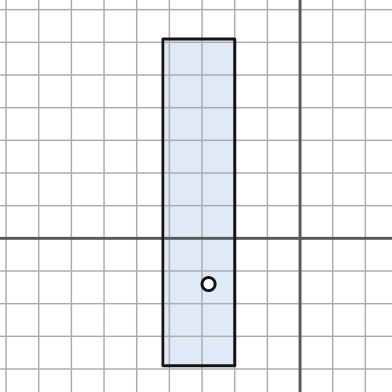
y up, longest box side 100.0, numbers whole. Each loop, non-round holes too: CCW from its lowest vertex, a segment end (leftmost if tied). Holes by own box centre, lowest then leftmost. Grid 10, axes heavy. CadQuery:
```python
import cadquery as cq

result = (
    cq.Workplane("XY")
    .moveTo(-42.0, -39.0)
    .lineTo(-20.0, -39.0)
    .lineTo(-20.0, 61.0)
    .lineTo(-42.0, 61.0)
    .close()
    .moveTo(-28.0, -14.0)
    .circle(2.0)
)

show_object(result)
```